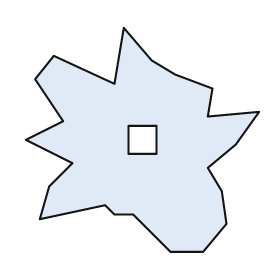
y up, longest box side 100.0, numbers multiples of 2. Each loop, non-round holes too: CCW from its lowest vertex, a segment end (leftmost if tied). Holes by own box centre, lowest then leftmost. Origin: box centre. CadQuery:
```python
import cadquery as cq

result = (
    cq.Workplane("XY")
    .moveTo(12.0, -48.0)
    .lineTo(26.0, -48.0)
    .lineTo(36.0, -36.0)
    .lineTo(34.0, -22.0)
    .lineTo(28.0, -12.0)
    .lineTo(40.0, -2.0)
    .lineTo(50.0, 12.0)
    .lineTo(28.0, 10.0)
    .lineTo(30.0, 22.0)
    .lineTo(14.0, 28.0)
    .lineTo(4.0, 34.0)
    .lineTo(-8.0, 48.0)
    .lineTo(-12.0, 24.0)
    .lineTo(-38.0, 36.0)
    .lineTo(-46.0, 26.0)
    .lineTo(-34.0, 8.0)
    .lineTo(-50.0, 0.0)
    .lineTo(-30.0, -10.0)
    .lineTo(-40.0, -20.0)
    .lineTo(-44.0, -34.0)
    .lineTo(-16.0, -28.0)
    .lineTo(-12.0, -32.0)
    .lineTo(-4.0, -32.0)
    .close()
    .moveTo(-6.0, -6.0)
    .lineTo(6.0, -6.0)
    .lineTo(6.0, 6.0)
    .lineTo(-6.0, 6.0)
    .close()
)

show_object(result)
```